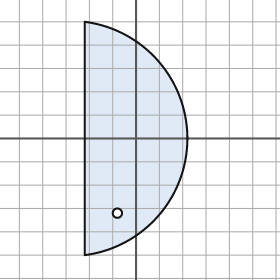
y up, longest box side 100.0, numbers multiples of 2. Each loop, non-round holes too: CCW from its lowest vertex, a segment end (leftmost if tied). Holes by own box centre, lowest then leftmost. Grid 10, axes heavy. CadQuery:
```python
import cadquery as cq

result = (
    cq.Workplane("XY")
    .moveTo(-22.0, -50.0)
    .threePointArc((22.0, 0.0), (-22.0, 50.0))
    .close()
    .moveTo(-8.0, -32.0)
    .circle(2.0)
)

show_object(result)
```